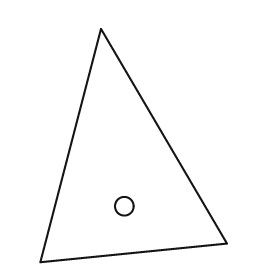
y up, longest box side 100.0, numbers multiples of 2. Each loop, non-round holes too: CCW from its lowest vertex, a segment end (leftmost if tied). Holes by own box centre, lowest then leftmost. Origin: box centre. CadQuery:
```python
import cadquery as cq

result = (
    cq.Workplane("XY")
    .moveTo(-40.0, -50.0)
    .lineTo(40.0, -42.0)
    .lineTo(-14.0, 50.0)
    .close()
    .moveTo(-4.0, -26.0)
    .circle(4.0)
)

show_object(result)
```